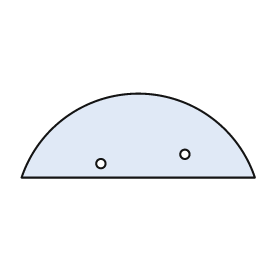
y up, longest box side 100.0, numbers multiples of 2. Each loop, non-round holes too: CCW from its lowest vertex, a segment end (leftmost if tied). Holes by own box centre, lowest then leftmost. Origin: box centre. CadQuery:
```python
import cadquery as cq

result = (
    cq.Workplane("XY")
    .moveTo(-50.0, -18.0)
    .lineTo(50.0, -18.0)
    .threePointArc((0.0, 18.0), (-50.0, -18.0))
    .close()
    .moveTo(-16.0, -12.0)
    .circle(2.0)
    .moveTo(20.0, -8.0)
    .circle(2.0)
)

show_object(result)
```